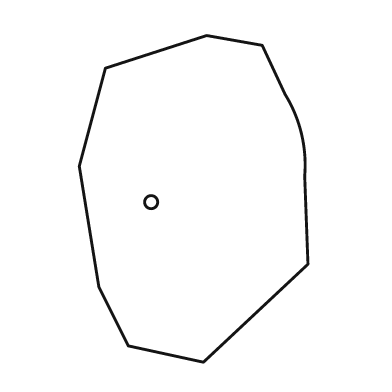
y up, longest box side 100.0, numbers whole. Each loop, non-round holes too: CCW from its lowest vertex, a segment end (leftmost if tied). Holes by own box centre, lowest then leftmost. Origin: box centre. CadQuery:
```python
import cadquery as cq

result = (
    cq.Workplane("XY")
    .moveTo(3.0, -50.0)
    .lineTo(35.0, -20.0)
    .lineTo(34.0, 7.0)
    .threePointArc((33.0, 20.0), (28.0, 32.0))
    .lineTo(21.0, 47.0)
    .lineTo(4.0, 50.0)
    .lineTo(-27.0, 40.0)
    .lineTo(-35.0, 10.0)
    .lineTo(-29.0, -27.0)
    .lineTo(-20.0, -45.0)
    .close()
    .moveTo(-13.0, -1.0)
    .circle(2.0)
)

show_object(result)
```